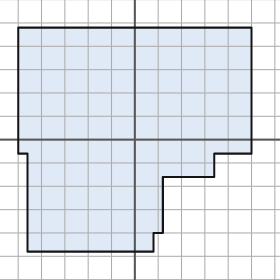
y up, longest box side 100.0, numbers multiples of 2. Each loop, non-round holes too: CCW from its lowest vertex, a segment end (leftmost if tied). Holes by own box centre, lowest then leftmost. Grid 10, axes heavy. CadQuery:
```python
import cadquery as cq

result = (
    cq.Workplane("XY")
    .moveTo(-46.0, -48.0)
    .lineTo(8.0, -48.0)
    .lineTo(8.0, -40.0)
    .lineTo(12.0, -40.0)
    .lineTo(12.0, -16.0)
    .lineTo(34.0, -16.0)
    .lineTo(34.0, -6.0)
    .lineTo(50.0, -6.0)
    .lineTo(50.0, 48.0)
    .lineTo(-50.0, 48.0)
    .lineTo(-50.0, -6.0)
    .lineTo(-46.0, -6.0)
    .close()
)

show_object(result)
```